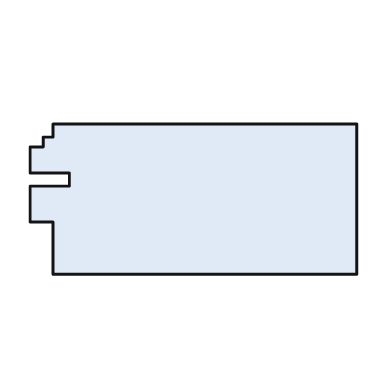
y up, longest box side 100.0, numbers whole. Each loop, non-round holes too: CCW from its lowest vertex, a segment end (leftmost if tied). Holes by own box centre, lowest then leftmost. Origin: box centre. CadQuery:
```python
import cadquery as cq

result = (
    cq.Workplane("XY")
    .moveTo(-43.0, -23.0)
    .lineTo(50.0, -23.0)
    .lineTo(50.0, 23.0)
    .lineTo(-43.0, 23.0)
    .lineTo(-43.0, 19.0)
    .lineTo(-46.0, 19.0)
    .lineTo(-46.0, 16.0)
    .lineTo(-50.0, 16.0)
    .lineTo(-50.0, 8.0)
    .lineTo(-38.0, 8.0)
    .lineTo(-38.0, 4.0)
    .lineTo(-50.0, 4.0)
    .lineTo(-50.0, -7.0)
    .lineTo(-43.0, -7.0)
    .close()
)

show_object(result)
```